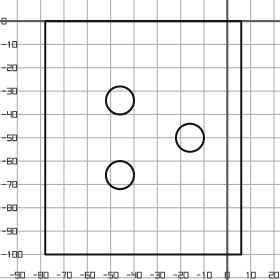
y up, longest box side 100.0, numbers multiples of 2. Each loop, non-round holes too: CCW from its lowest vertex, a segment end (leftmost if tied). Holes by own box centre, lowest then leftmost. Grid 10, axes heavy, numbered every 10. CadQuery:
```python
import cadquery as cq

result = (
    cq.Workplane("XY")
    .moveTo(-78.0, -100.0)
    .lineTo(6.0, -100.0)
    .lineTo(6.0, 0.0)
    .lineTo(-78.0, 0.0)
    .close()
    .moveTo(-46.0, -66.0)
    .circle(6.0)
    .moveTo(-16.0, -50.0)
    .circle(6.0)
    .moveTo(-46.0, -34.0)
    .circle(6.0)
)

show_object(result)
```